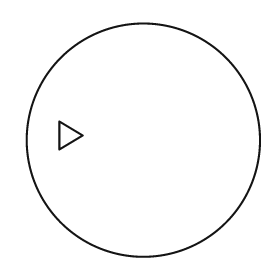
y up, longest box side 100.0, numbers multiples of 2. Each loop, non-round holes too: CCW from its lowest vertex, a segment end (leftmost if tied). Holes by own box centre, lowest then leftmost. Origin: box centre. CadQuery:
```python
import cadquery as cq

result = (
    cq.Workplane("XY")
    .moveTo(0.0, 0.0)
    .circle(50.0)
    .moveTo(-36.0, -4.0)
    .lineTo(-26.0, 2.0)
    .lineTo(-36.0, 8.0)
    .close()
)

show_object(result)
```